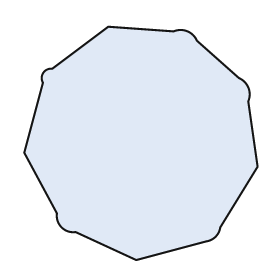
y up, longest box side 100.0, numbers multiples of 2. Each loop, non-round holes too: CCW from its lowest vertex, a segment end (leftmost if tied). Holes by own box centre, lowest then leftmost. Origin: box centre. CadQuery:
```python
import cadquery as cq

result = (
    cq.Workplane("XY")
    .moveTo(-2.0, -50.0)
    .lineTo(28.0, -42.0)
    .threePointArc((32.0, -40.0), (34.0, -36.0))
    .lineTo(50.0, -10.0)
    .lineTo(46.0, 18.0)
    .threePointArc((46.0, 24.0), (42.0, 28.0))
    .lineTo(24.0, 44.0)
    .threePointArc((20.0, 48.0), (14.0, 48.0))
    .lineTo(-14.0, 50.0)
    .lineTo(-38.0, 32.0)
    .threePointArc((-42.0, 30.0), (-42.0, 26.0))
    .lineTo(-50.0, -4.0)
    .lineTo(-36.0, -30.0)
    .threePointArc((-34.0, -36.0), (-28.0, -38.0))
    .close()
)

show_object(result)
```